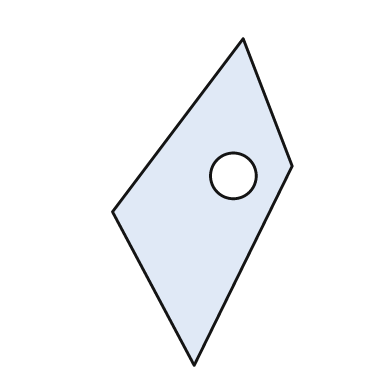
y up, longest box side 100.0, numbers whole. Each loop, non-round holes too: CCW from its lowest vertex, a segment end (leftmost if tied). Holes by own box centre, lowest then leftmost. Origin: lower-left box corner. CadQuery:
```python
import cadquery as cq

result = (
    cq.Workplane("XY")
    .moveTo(25.0, 0.0)
    .lineTo(55.0, 61.0)
    .lineTo(40.0, 100.0)
    .lineTo(0.0, 47.0)
    .close()
    .moveTo(37.0, 58.0)
    .circle(7.0)
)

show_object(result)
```